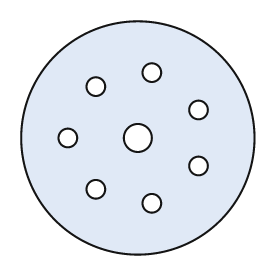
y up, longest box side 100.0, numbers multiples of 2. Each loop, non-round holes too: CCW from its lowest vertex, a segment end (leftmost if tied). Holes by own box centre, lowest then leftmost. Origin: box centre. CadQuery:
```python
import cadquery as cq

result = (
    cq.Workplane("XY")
    .moveTo(0.0, 0.0)
    .circle(50.0)
    .moveTo(6.0, -28.0)
    .circle(4.0)
    .moveTo(-18.0, -22.0)
    .circle(4.0)
    .moveTo(26.0, -12.0)
    .circle(4.0)
    .moveTo(-30.0, 0.0)
    .circle(4.0)
    .moveTo(0.0, 0.0)
    .circle(6.0)
    .moveTo(26.0, 12.0)
    .circle(4.0)
    .moveTo(-18.0, 22.0)
    .circle(4.0)
    .moveTo(6.0, 28.0)
    .circle(4.0)
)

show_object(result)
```